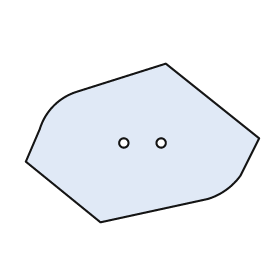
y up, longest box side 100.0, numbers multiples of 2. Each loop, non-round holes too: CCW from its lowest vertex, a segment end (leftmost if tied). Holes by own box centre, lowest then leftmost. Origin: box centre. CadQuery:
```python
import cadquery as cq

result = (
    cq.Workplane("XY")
    .moveTo(-18.0, -34.0)
    .lineTo(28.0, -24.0)
    .threePointArc((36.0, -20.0), (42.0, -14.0))
    .lineTo(50.0, 2.0)
    .lineTo(10.0, 34.0)
    .lineTo(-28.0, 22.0)
    .threePointArc((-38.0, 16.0), (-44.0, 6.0))
    .lineTo(-50.0, -8.0)
    .close()
    .moveTo(-8.0, 0.0)
    .circle(2.0)
    .moveTo(8.0, 0.0)
    .circle(2.0)
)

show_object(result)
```